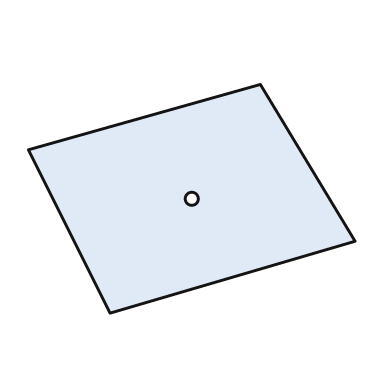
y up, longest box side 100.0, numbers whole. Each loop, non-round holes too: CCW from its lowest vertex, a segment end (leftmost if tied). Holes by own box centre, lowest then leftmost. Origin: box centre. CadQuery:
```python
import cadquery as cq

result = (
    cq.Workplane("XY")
    .moveTo(-25.0, -35.0)
    .lineTo(50.0, -13.0)
    .lineTo(21.0, 35.0)
    .lineTo(-50.0, 15.0)
    .close()
    .moveTo(0.0, 0.0)
    .circle(2.0)
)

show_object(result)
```